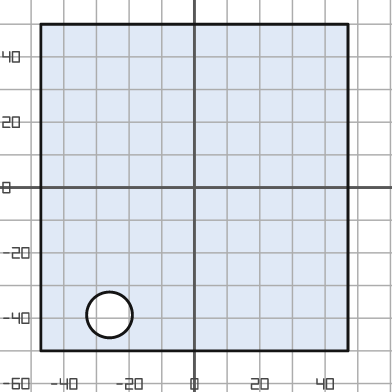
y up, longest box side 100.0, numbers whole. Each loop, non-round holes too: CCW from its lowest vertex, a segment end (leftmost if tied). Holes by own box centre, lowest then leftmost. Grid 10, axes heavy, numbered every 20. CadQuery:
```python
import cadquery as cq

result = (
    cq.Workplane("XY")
    .moveTo(-47.0, -50.0)
    .lineTo(47.0, -50.0)
    .lineTo(47.0, 50.0)
    .lineTo(-47.0, 50.0)
    .close()
    .moveTo(-26.0, -39.0)
    .circle(7.0)
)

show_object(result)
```